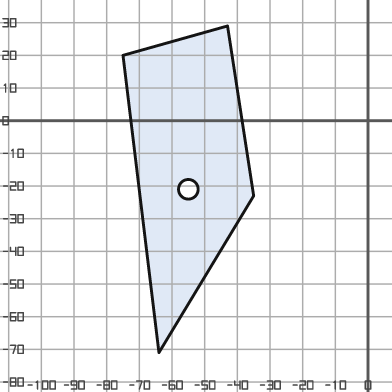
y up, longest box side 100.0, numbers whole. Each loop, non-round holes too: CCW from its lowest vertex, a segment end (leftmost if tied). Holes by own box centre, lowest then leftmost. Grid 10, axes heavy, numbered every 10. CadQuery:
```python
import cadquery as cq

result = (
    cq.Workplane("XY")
    .moveTo(-64.0, -71.0)
    .lineTo(-35.0, -23.0)
    .lineTo(-43.0, 29.0)
    .lineTo(-75.0, 20.0)
    .close()
    .moveTo(-55.0, -21.0)
    .circle(3.0)
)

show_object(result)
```